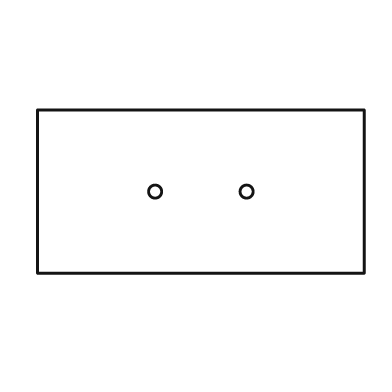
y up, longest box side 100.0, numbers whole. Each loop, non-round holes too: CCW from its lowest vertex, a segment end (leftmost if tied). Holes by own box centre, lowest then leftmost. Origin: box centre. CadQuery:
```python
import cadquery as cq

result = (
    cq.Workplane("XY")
    .moveTo(-50.0, -25.0)
    .lineTo(50.0, -25.0)
    .lineTo(50.0, 25.0)
    .lineTo(-50.0, 25.0)
    .close()
    .moveTo(-14.0, 0.0)
    .circle(2.0)
    .moveTo(14.0, 0.0)
    .circle(2.0)
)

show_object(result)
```